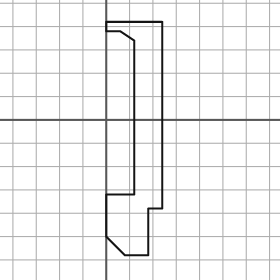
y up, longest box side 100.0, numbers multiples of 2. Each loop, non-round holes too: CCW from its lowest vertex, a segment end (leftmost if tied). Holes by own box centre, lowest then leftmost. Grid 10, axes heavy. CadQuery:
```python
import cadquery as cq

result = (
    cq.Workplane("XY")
    .moveTo(8.0, -58.0)
    .lineTo(18.0, -58.0)
    .lineTo(18.0, -38.0)
    .lineTo(24.0, -38.0)
    .lineTo(24.0, 42.0)
    .lineTo(0.0, 42.0)
    .lineTo(0.0, 38.0)
    .lineTo(6.0, 38.0)
    .lineTo(12.0, 34.0)
    .lineTo(12.0, -32.0)
    .lineTo(0.0, -32.0)
    .lineTo(0.0, -50.0)
    .close()
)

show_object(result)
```